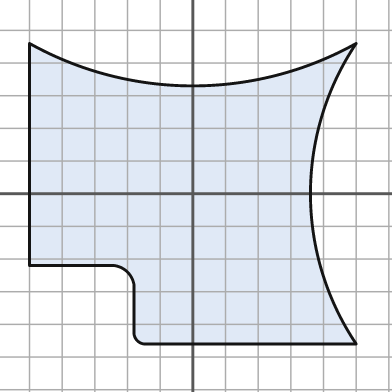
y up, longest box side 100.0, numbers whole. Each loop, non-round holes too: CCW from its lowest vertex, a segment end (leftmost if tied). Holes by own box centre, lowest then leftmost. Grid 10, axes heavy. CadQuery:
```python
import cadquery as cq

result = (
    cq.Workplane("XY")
    .moveTo(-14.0, -46.0)
    .lineTo(50.0, -46.0)
    .threePointArc((36.0, 0.0), (50.0, 46.0))
    .threePointArc((0.0, 33.0), (-50.0, 46.0))
    .lineTo(-50.0, -22.0)
    .lineTo(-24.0, -22.0)
    .threePointArc((-20.0, -24.0), (-18.0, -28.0))
    .lineTo(-18.0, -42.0)
    .threePointArc((-17.0, -45.0), (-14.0, -46.0))
    .close()
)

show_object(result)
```